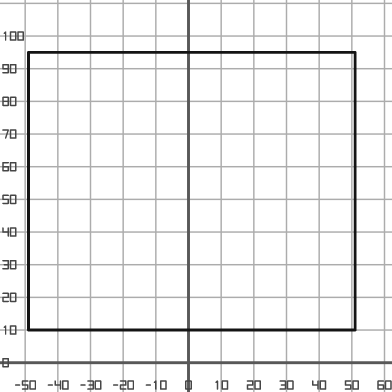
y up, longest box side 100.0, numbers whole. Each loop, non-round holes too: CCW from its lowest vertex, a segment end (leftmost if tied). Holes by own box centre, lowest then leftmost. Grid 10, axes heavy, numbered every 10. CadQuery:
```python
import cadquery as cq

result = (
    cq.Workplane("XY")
    .moveTo(-49.0, 10.0)
    .lineTo(51.0, 10.0)
    .lineTo(51.0, 95.0)
    .lineTo(-49.0, 95.0)
    .close()
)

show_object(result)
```